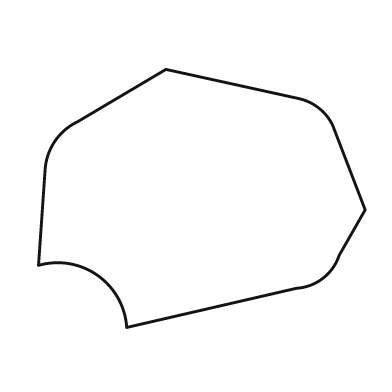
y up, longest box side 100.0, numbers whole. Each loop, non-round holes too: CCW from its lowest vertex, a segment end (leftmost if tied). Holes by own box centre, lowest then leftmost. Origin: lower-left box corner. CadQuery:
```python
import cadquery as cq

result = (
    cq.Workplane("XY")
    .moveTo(27.0, 0.0)
    .lineTo(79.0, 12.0)
    .threePointArc((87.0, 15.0), (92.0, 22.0))
    .lineTo(100.0, 36.0)
    .lineTo(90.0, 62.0)
    .threePointArc((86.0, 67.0), (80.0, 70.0))
    .lineTo(39.0, 79.0)
    .lineTo(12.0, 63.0)
    .threePointArc((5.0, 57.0), (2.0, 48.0))
    .lineTo(0.0, 19.0)
    .threePointArc((18.0, 16.0), (27.0, 0.0))
    .close()
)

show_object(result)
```